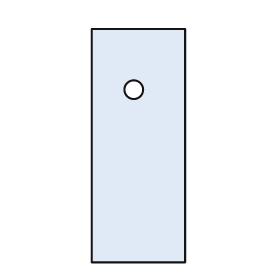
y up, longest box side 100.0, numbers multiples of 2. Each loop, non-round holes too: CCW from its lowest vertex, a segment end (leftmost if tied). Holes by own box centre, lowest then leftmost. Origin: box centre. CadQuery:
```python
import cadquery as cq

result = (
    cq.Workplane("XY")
    .moveTo(-20.0, -50.0)
    .lineTo(20.0, -50.0)
    .lineTo(20.0, 50.0)
    .lineTo(-20.0, 50.0)
    .close()
    .moveTo(-2.0, 24.0)
    .circle(4.0)
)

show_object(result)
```